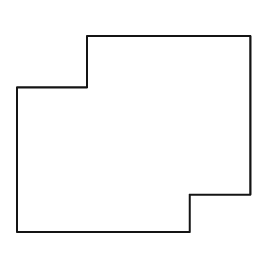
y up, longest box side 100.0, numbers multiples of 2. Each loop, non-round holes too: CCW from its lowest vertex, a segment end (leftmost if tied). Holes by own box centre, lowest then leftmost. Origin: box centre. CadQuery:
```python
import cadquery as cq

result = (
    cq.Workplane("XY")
    .moveTo(-50.0, -42.0)
    .lineTo(24.0, -42.0)
    .lineTo(24.0, -26.0)
    .lineTo(50.0, -26.0)
    .lineTo(50.0, 42.0)
    .lineTo(-20.0, 42.0)
    .lineTo(-20.0, 20.0)
    .lineTo(-50.0, 20.0)
    .close()
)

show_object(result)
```